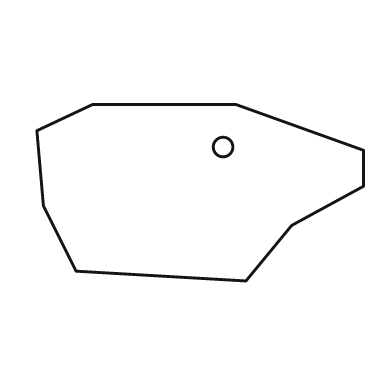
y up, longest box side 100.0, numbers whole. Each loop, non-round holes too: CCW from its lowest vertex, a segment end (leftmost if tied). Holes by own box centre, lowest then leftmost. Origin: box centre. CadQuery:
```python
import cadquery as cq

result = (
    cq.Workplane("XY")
    .moveTo(14.0, -27.0)
    .lineTo(28.0, -10.0)
    .lineTo(50.0, 2.0)
    .lineTo(50.0, 13.0)
    .lineTo(11.0, 27.0)
    .lineTo(-33.0, 27.0)
    .lineTo(-50.0, 19.0)
    .lineTo(-48.0, -4.0)
    .lineTo(-38.0, -24.0)
    .close()
    .moveTo(7.0, 14.0)
    .circle(3.0)
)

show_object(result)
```